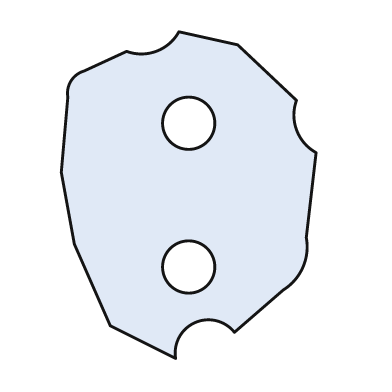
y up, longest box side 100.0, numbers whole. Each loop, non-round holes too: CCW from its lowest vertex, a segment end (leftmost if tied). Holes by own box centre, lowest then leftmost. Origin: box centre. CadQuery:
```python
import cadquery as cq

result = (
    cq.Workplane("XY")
    .moveTo(-4.0, -50.0)
    .threePointArc((2.0, -39.0), (14.0, -42.0))
    .lineTo(29.0, -29.0)
    .threePointArc((35.0, -22.0), (36.0, -13.0))
    .lineTo(39.0, 13.0)
    .threePointArc((33.0, 20.0), (33.0, 29.0))
    .lineTo(15.0, 46.0)
    .lineTo(-3.0, 50.0)
    .threePointArc((-10.0, 44.0), (-19.0, 44.0))
    .lineTo(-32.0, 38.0)
    .threePointArc((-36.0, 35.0), (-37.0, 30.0))
    .lineTo(-39.0, 7.0)
    .lineTo(-35.0, -15.0)
    .lineTo(-24.0, -40.0)
    .close()
    .moveTo(0.0, -22.0)
    .circle(8.0)
    .moveTo(0.0, 22.0)
    .circle(8.0)
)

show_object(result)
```